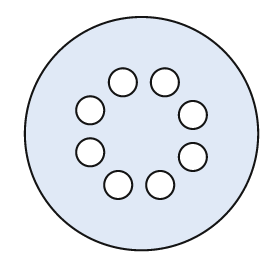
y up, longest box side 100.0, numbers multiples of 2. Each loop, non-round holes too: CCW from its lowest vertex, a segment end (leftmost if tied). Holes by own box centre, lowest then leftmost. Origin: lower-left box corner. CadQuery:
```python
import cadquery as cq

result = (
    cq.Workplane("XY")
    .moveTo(50.0, 50.0)
    .circle(50.0)
    .moveTo(40.0, 28.0)
    .circle(6.0)
    .moveTo(58.0, 28.0)
    .circle(6.0)
    .moveTo(72.0, 40.0)
    .circle(6.0)
    .moveTo(28.0, 42.0)
    .circle(6.0)
    .moveTo(72.0, 58.0)
    .circle(6.0)
    .moveTo(28.0, 60.0)
    .circle(6.0)
    .moveTo(42.0, 72.0)
    .circle(6.0)
    .moveTo(60.0, 72.0)
    .circle(6.0)
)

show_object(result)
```